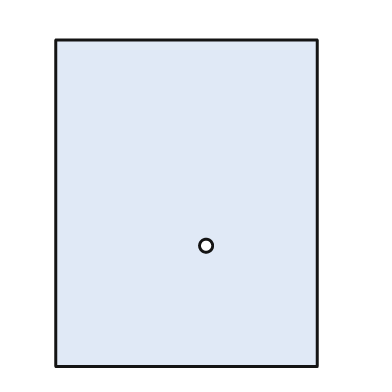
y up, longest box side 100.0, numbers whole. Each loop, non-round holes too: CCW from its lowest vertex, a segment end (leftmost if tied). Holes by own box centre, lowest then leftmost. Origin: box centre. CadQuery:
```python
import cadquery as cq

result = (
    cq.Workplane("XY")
    .moveTo(-40.0, -50.0)
    .lineTo(40.0, -50.0)
    .lineTo(40.0, 50.0)
    .lineTo(-40.0, 50.0)
    .close()
    .moveTo(6.0, -13.0)
    .circle(2.0)
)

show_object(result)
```